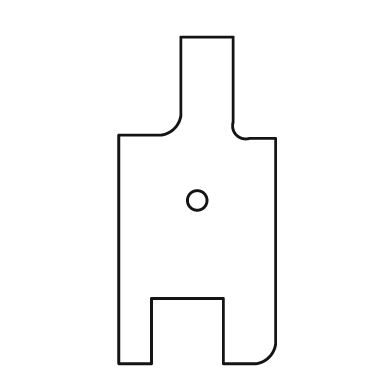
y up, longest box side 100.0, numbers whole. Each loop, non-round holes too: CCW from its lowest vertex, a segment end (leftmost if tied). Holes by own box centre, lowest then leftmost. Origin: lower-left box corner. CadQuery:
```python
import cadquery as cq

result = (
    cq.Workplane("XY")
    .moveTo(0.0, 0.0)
    .lineTo(10.0, 0.0)
    .lineTo(10.0, 20.0)
    .lineTo(32.0, 20.0)
    .lineTo(32.0, 0.0)
    .lineTo(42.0, 0.0)
    .threePointArc((46.0, 2.0), (48.0, 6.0))
    .lineTo(48.0, 69.0)
    .lineTo(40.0, 69.0)
    .threePointArc((36.0, 70.0), (35.0, 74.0))
    .lineTo(35.0, 100.0)
    .lineTo(19.0, 100.0)
    .lineTo(19.0, 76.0)
    .threePointArc((17.0, 72.0), (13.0, 70.0))
    .lineTo(0.0, 70.0)
    .close()
    .moveTo(24.0, 50.0)
    .circle(3.0)
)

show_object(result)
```